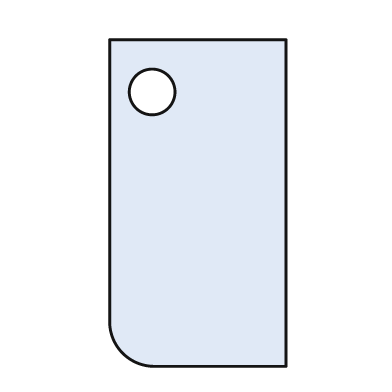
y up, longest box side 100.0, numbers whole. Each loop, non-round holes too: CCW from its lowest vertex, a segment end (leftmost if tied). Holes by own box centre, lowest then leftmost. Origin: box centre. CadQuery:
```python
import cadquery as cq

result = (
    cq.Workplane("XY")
    .moveTo(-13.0, -50.0)
    .lineTo(27.0, -50.0)
    .lineTo(27.0, 50.0)
    .lineTo(-27.0, 50.0)
    .lineTo(-27.0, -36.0)
    .threePointArc((-23.0, -46.0), (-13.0, -50.0))
    .close()
    .moveTo(-14.0, 34.0)
    .circle(7.0)
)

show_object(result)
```